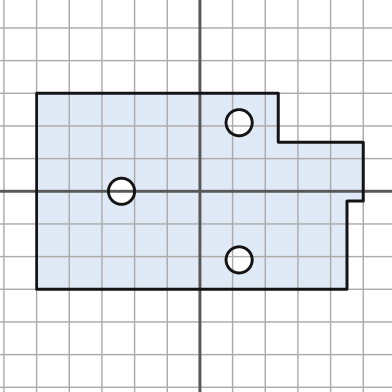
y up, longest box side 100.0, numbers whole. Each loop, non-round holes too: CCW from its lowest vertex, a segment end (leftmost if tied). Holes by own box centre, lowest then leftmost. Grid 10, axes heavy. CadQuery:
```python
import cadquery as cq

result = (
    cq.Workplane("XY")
    .moveTo(-50.0, -30.0)
    .lineTo(45.0, -30.0)
    .lineTo(45.0, -3.0)
    .lineTo(50.0, -3.0)
    .lineTo(50.0, 15.0)
    .lineTo(24.0, 15.0)
    .lineTo(24.0, 30.0)
    .lineTo(-50.0, 30.0)
    .close()
    .moveTo(12.0, -21.0)
    .circle(4.0)
    .moveTo(-24.0, 0.0)
    .circle(4.0)
    .moveTo(12.0, 21.0)
    .circle(4.0)
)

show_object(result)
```